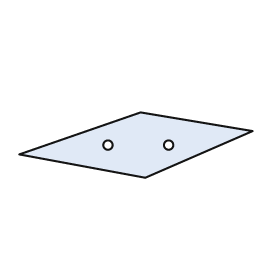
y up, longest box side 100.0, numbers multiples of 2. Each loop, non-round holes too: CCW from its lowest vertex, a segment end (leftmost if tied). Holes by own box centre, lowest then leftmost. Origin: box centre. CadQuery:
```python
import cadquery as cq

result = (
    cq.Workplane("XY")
    .moveTo(4.0, -14.0)
    .lineTo(50.0, 6.0)
    .lineTo(2.0, 14.0)
    .lineTo(-50.0, -4.0)
    .close()
    .moveTo(-12.0, 0.0)
    .circle(2.0)
    .moveTo(14.0, 0.0)
    .circle(2.0)
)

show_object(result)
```